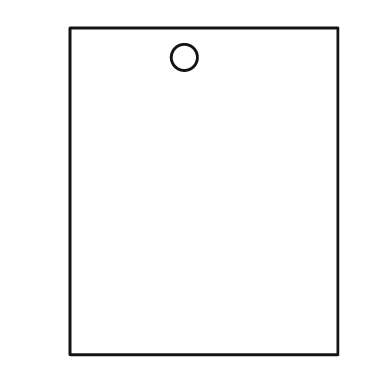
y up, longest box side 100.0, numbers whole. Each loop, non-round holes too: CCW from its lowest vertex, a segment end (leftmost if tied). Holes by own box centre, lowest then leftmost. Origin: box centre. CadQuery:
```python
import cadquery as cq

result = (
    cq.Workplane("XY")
    .moveTo(-41.0, -50.0)
    .lineTo(41.0, -50.0)
    .lineTo(41.0, 50.0)
    .lineTo(-41.0, 50.0)
    .close()
    .moveTo(-6.0, 41.0)
    .circle(4.0)
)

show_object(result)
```